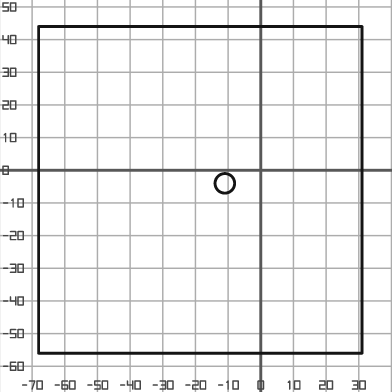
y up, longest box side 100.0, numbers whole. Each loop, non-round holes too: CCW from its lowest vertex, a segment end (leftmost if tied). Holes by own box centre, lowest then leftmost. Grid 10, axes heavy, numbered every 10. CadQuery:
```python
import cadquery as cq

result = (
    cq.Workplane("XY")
    .moveTo(-68.0, -56.0)
    .lineTo(31.0, -56.0)
    .lineTo(31.0, 44.0)
    .lineTo(-68.0, 44.0)
    .close()
    .moveTo(-11.0, -4.0)
    .circle(3.0)
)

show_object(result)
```